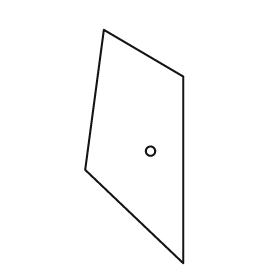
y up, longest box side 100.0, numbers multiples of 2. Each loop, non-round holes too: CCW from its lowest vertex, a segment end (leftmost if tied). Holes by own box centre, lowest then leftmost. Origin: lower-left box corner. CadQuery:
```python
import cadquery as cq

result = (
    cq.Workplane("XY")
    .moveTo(42.0, 0.0)
    .lineTo(42.0, 80.0)
    .lineTo(8.0, 100.0)
    .lineTo(0.0, 40.0)
    .close()
    .moveTo(28.0, 48.0)
    .circle(2.0)
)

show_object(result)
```